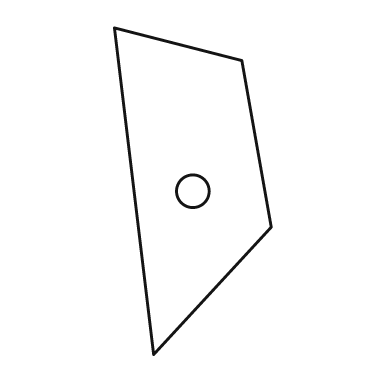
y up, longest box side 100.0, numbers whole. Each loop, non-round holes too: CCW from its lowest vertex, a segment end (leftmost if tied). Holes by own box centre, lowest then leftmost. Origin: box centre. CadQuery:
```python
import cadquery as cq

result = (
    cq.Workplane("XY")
    .moveTo(-12.0, -50.0)
    .lineTo(24.0, -11.0)
    .lineTo(15.0, 40.0)
    .lineTo(-24.0, 50.0)
    .close()
    .moveTo(0.0, 0.0)
    .circle(5.0)
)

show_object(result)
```